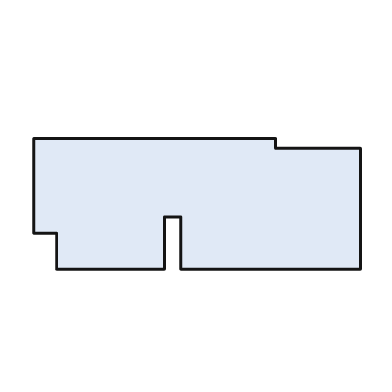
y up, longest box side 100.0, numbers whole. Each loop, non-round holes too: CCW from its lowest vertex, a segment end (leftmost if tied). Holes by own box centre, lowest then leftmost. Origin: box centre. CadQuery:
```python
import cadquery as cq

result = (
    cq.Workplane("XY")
    .moveTo(-43.0, -20.0)
    .lineTo(-10.0, -20.0)
    .lineTo(-10.0, -4.0)
    .lineTo(-5.0, -4.0)
    .lineTo(-5.0, -20.0)
    .lineTo(50.0, -20.0)
    .lineTo(50.0, 17.0)
    .lineTo(24.0, 17.0)
    .lineTo(24.0, 20.0)
    .lineTo(-50.0, 20.0)
    .lineTo(-50.0, -9.0)
    .lineTo(-43.0, -9.0)
    .close()
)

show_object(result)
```